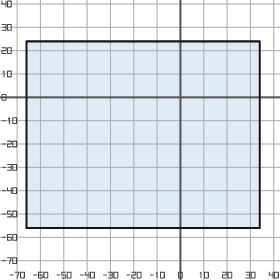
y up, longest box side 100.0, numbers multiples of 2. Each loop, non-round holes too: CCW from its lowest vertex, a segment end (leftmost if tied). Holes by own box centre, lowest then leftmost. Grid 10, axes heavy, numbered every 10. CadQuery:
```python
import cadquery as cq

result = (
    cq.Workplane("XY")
    .moveTo(-66.0, -56.0)
    .lineTo(34.0, -56.0)
    .lineTo(34.0, 24.0)
    .lineTo(-66.0, 24.0)
    .close()
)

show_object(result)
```